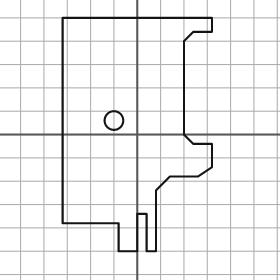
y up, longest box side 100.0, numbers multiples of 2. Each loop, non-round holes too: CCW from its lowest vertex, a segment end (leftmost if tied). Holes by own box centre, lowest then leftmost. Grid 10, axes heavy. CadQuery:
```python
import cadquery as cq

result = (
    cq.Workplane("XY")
    .moveTo(-8.0, -50.0)
    .lineTo(0.0, -50.0)
    .lineTo(0.0, -34.0)
    .lineTo(4.0, -34.0)
    .lineTo(4.0, -50.0)
    .lineTo(8.0, -50.0)
    .lineTo(8.0, -24.0)
    .lineTo(14.0, -18.0)
    .lineTo(26.0, -18.0)
    .lineTo(32.0, -14.0)
    .lineTo(32.0, -4.0)
    .lineTo(24.0, -4.0)
    .lineTo(20.0, 0.0)
    .lineTo(20.0, 40.0)
    .lineTo(24.0, 44.0)
    .lineTo(32.0, 44.0)
    .lineTo(32.0, 50.0)
    .lineTo(-32.0, 50.0)
    .lineTo(-32.0, -38.0)
    .lineTo(-8.0, -38.0)
    .close()
    .moveTo(-10.0, 6.0)
    .circle(4.0)
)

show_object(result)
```